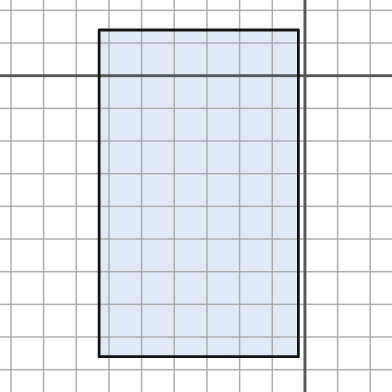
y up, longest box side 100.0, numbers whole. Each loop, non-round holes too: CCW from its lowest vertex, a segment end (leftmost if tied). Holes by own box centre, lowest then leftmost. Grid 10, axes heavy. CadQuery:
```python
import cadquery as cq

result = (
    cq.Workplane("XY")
    .moveTo(-63.0, -86.0)
    .lineTo(-2.0, -86.0)
    .lineTo(-2.0, 14.0)
    .lineTo(-63.0, 14.0)
    .close()
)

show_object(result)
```